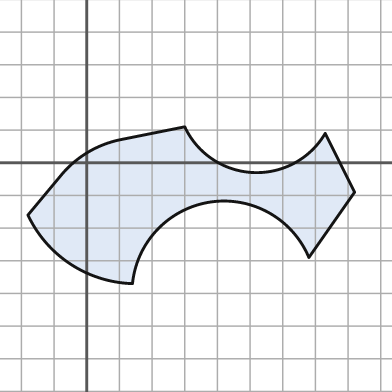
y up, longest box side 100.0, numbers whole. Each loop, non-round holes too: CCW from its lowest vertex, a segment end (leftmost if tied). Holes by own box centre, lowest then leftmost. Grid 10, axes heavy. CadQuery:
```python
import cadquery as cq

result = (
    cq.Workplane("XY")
    .moveTo(14.0, -37.0)
    .threePointArc((38.0, -12.0), (68.0, -29.0))
    .lineTo(82.0, -9.0)
    .lineTo(73.0, 9.0)
    .threePointArc((51.0, -3.0), (30.0, 11.0))
    .lineTo(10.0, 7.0)
    .threePointArc((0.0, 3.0), (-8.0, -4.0))
    .lineTo(-18.0, -16.0)
    .threePointArc((-5.0, -31.0), (14.0, -37.0))
    .close()
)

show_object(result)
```